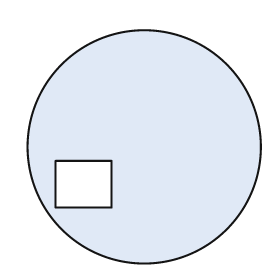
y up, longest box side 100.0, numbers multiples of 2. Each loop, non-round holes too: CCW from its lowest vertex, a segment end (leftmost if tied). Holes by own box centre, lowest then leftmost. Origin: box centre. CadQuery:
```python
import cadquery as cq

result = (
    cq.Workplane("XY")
    .moveTo(0.0, 0.0)
    .circle(50.0)
    .moveTo(-38.0, -26.0)
    .lineTo(-14.0, -26.0)
    .lineTo(-14.0, -6.0)
    .lineTo(-38.0, -6.0)
    .close()
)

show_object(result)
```